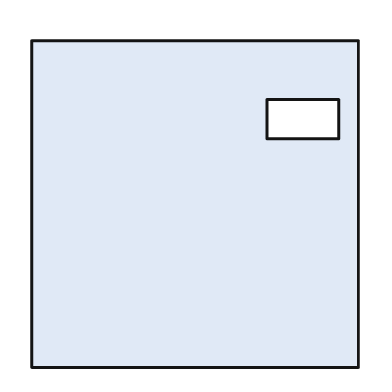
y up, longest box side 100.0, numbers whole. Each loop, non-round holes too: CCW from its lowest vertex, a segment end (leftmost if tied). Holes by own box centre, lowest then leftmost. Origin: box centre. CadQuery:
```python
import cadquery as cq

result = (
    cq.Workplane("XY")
    .moveTo(-50.0, -50.0)
    .lineTo(50.0, -50.0)
    .lineTo(50.0, 50.0)
    .lineTo(-50.0, 50.0)
    .close()
    .moveTo(22.0, 20.0)
    .lineTo(44.0, 20.0)
    .lineTo(44.0, 32.0)
    .lineTo(22.0, 32.0)
    .close()
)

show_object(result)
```